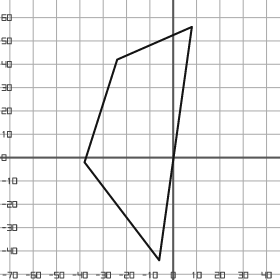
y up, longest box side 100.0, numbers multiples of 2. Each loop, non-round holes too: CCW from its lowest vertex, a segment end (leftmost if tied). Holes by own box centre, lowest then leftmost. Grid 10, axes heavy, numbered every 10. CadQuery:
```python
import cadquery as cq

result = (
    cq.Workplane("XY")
    .moveTo(-6.0, -44.0)
    .lineTo(8.0, 56.0)
    .lineTo(-24.0, 42.0)
    .lineTo(-38.0, -2.0)
    .close()
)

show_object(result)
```